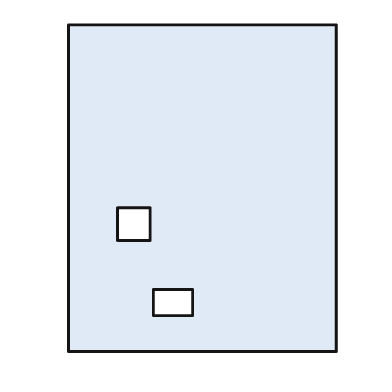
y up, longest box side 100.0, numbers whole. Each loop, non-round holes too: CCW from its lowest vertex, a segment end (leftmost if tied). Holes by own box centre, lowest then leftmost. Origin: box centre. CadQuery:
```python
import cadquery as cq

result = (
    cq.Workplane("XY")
    .moveTo(-41.0, -50.0)
    .lineTo(41.0, -50.0)
    .lineTo(41.0, 50.0)
    .lineTo(-41.0, 50.0)
    .close()
    .moveTo(-15.0, -39.0)
    .lineTo(-3.0, -39.0)
    .lineTo(-3.0, -31.0)
    .lineTo(-15.0, -31.0)
    .close()
    .moveTo(-26.0, -16.0)
    .lineTo(-16.0, -16.0)
    .lineTo(-16.0, -6.0)
    .lineTo(-26.0, -6.0)
    .close()
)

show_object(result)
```